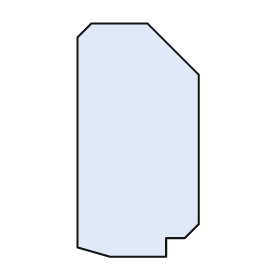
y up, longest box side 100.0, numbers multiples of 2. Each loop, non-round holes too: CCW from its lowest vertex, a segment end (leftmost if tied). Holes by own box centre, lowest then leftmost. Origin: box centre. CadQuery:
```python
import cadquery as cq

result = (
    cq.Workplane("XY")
    .moveTo(-12.0, -50.0)
    .lineTo(12.0, -50.0)
    .lineTo(12.0, -42.0)
    .lineTo(20.0, -42.0)
    .lineTo(26.0, -36.0)
    .lineTo(26.0, 28.0)
    .lineTo(4.0, 50.0)
    .lineTo(-20.0, 50.0)
    .lineTo(-26.0, 44.0)
    .lineTo(-26.0, -46.0)
    .close()
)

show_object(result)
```